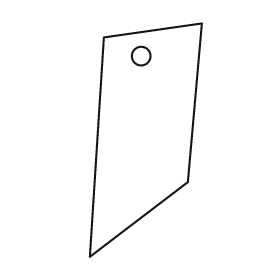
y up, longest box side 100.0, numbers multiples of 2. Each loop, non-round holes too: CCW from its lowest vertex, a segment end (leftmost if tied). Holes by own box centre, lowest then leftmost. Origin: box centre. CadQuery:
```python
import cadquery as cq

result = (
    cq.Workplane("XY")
    .moveTo(-24.0, -50.0)
    .lineTo(18.0, -18.0)
    .lineTo(24.0, 50.0)
    .lineTo(-18.0, 44.0)
    .close()
    .moveTo(-2.0, 36.0)
    .circle(4.0)
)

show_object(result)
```